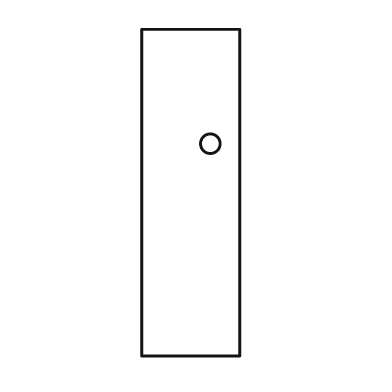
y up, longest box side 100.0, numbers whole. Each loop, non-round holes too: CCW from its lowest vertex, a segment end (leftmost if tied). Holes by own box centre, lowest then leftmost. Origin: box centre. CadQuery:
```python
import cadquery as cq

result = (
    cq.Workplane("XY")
    .moveTo(-15.0, -50.0)
    .lineTo(15.0, -50.0)
    .lineTo(15.0, 50.0)
    .lineTo(-15.0, 50.0)
    .close()
    .moveTo(6.0, 15.0)
    .circle(3.0)
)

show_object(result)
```